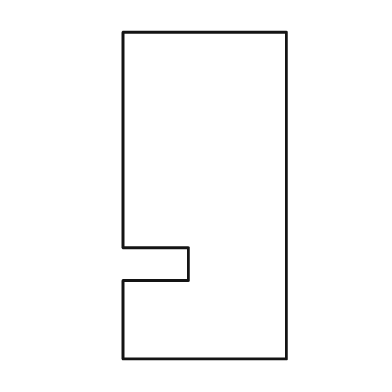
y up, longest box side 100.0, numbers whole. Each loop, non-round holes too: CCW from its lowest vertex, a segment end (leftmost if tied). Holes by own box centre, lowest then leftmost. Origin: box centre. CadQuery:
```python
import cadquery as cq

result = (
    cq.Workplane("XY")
    .moveTo(-25.0, -50.0)
    .lineTo(25.0, -50.0)
    .lineTo(25.0, 50.0)
    .lineTo(-25.0, 50.0)
    .lineTo(-25.0, -16.0)
    .lineTo(-5.0, -16.0)
    .lineTo(-5.0, -26.0)
    .lineTo(-25.0, -26.0)
    .close()
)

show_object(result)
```